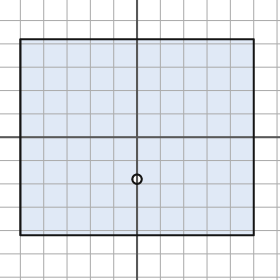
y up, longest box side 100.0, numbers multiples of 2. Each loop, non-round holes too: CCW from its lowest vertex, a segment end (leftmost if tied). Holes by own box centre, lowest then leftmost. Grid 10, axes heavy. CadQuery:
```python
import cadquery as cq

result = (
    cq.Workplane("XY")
    .moveTo(-50.0, -42.0)
    .lineTo(50.0, -42.0)
    .lineTo(50.0, 42.0)
    .lineTo(-50.0, 42.0)
    .close()
    .moveTo(0.0, -18.0)
    .circle(2.0)
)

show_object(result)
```